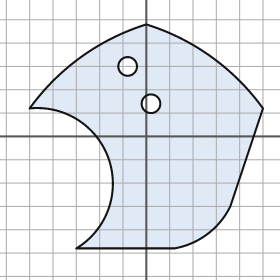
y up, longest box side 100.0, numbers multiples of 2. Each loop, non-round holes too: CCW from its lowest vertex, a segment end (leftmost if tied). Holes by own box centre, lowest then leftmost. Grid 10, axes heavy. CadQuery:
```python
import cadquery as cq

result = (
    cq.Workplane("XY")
    .moveTo(-30.0, -48.0)
    .lineTo(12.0, -48.0)
    .threePointArc((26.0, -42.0), (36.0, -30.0))
    .lineTo(50.0, 12.0)
    .threePointArc((28.0, 34.0), (0.0, 48.0))
    .threePointArc((-28.0, 34.0), (-50.0, 12.0))
    .threePointArc((-16.0, -10.0), (-30.0, -48.0))
    .close()
    .moveTo(2.0, 14.0)
    .circle(4.0)
    .moveTo(-8.0, 30.0)
    .circle(4.0)
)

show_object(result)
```